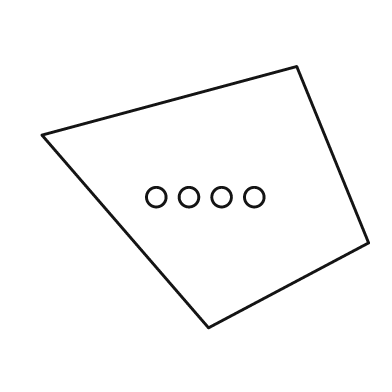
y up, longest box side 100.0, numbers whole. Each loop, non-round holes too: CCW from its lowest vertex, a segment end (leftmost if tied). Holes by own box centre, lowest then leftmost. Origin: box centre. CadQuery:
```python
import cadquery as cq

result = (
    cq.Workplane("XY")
    .moveTo(1.0, -40.0)
    .lineTo(50.0, -14.0)
    .lineTo(28.0, 40.0)
    .lineTo(-50.0, 19.0)
    .close()
    .moveTo(-15.0, 0.0)
    .circle(3.0)
    .moveTo(-5.0, 0.0)
    .circle(3.0)
    .moveTo(5.0, 0.0)
    .circle(3.0)
    .moveTo(15.0, 0.0)
    .circle(3.0)
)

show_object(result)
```